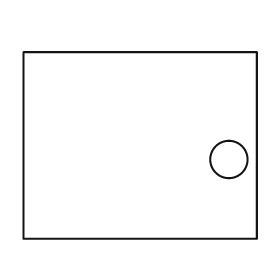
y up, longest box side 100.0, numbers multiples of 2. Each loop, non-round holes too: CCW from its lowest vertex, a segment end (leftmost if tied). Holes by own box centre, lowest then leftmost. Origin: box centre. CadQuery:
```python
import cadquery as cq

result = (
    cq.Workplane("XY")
    .moveTo(-50.0, -40.0)
    .lineTo(50.0, -40.0)
    .lineTo(50.0, 40.0)
    .lineTo(-50.0, 40.0)
    .close()
    .moveTo(38.0, -6.0)
    .circle(8.0)
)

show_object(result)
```